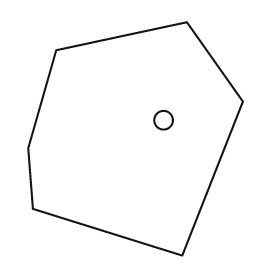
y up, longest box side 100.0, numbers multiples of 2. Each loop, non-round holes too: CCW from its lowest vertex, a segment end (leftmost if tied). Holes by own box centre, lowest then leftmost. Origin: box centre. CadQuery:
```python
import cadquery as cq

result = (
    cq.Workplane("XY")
    .moveTo(20.0, -50.0)
    .lineTo(46.0, 16.0)
    .lineTo(22.0, 50.0)
    .lineTo(-34.0, 38.0)
    .lineTo(-46.0, -4.0)
    .lineTo(-44.0, -30.0)
    .close()
    .moveTo(12.0, 8.0)
    .circle(4.0)
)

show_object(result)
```